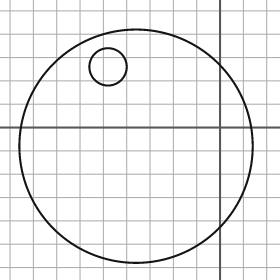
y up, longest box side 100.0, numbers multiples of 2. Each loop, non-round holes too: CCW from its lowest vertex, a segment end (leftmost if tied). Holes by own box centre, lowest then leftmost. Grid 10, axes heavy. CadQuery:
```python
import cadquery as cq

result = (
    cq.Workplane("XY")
    .moveTo(-36.0, -8.0)
    .circle(50.0)
    .moveTo(-48.0, 26.0)
    .circle(8.0)
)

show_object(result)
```